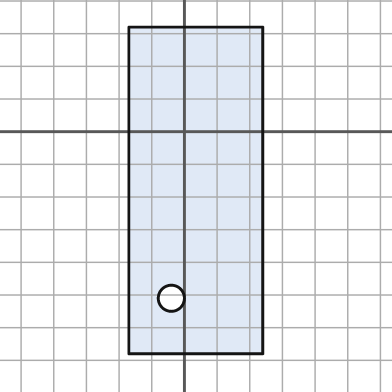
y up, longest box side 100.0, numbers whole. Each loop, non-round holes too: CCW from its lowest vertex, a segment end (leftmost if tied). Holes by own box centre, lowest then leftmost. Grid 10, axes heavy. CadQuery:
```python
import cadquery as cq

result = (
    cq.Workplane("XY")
    .moveTo(-17.0, -68.0)
    .lineTo(24.0, -68.0)
    .lineTo(24.0, 32.0)
    .lineTo(-17.0, 32.0)
    .close()
    .moveTo(-4.0, -51.0)
    .circle(4.0)
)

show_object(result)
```